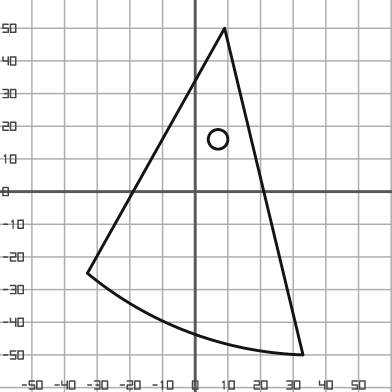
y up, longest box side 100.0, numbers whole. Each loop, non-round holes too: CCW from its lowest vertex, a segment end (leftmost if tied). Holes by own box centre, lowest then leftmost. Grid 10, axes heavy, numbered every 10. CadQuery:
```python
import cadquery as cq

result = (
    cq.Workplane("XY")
    .moveTo(33.0, -50.0)
    .lineTo(9.0, 50.0)
    .lineTo(-33.0, -25.0)
    .threePointArc((-2.0, -43.0), (33.0, -50.0))
    .close()
    .moveTo(7.0, 16.0)
    .circle(3.0)
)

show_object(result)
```